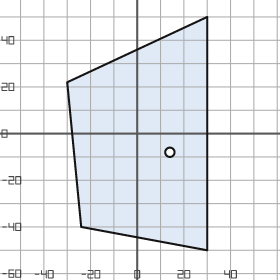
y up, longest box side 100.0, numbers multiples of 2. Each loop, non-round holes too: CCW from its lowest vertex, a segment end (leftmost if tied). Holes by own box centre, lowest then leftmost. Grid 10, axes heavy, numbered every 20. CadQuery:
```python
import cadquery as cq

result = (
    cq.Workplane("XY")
    .moveTo(30.0, -50.0)
    .lineTo(30.0, 50.0)
    .lineTo(-30.0, 22.0)
    .lineTo(-24.0, -40.0)
    .close()
    .moveTo(14.0, -8.0)
    .circle(2.0)
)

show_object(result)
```